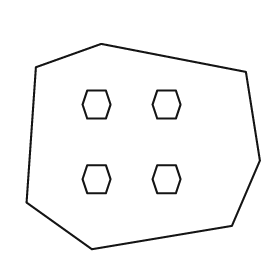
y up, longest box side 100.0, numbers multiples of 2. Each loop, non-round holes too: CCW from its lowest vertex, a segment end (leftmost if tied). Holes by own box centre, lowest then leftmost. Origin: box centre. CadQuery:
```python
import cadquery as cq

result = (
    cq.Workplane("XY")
    .moveTo(-22.0, -44.0)
    .lineTo(38.0, -34.0)
    .lineTo(50.0, -6.0)
    .lineTo(44.0, 32.0)
    .lineTo(-18.0, 44.0)
    .lineTo(-46.0, 34.0)
    .lineTo(-50.0, -24.0)
    .close()
    .moveTo(-24.0, -20.0)
    .lineTo(-16.0, -20.0)
    .lineTo(-14.0, -14.0)
    .lineTo(-16.0, -8.0)
    .lineTo(-24.0, -8.0)
    .lineTo(-26.0, -14.0)
    .close()
    .moveTo(6.0, -20.0)
    .lineTo(14.0, -20.0)
    .lineTo(16.0, -14.0)
    .lineTo(14.0, -8.0)
    .lineTo(6.0, -8.0)
    .lineTo(4.0, -14.0)
    .close()
    .moveTo(-24.0, 12.0)
    .lineTo(-16.0, 12.0)
    .lineTo(-14.0, 18.0)
    .lineTo(-16.0, 24.0)
    .lineTo(-24.0, 24.0)
    .lineTo(-26.0, 18.0)
    .close()
    .moveTo(6.0, 12.0)
    .lineTo(14.0, 12.0)
    .lineTo(16.0, 18.0)
    .lineTo(14.0, 24.0)
    .lineTo(6.0, 24.0)
    .lineTo(4.0, 18.0)
    .close()
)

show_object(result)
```